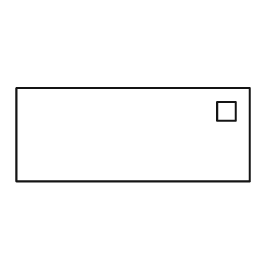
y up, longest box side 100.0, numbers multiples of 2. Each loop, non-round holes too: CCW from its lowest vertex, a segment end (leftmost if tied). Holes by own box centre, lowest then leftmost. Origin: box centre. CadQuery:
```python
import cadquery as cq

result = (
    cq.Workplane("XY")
    .moveTo(-50.0, -20.0)
    .lineTo(50.0, -20.0)
    .lineTo(50.0, 20.0)
    .lineTo(-50.0, 20.0)
    .close()
    .moveTo(36.0, 6.0)
    .lineTo(44.0, 6.0)
    .lineTo(44.0, 14.0)
    .lineTo(36.0, 14.0)
    .close()
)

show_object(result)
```